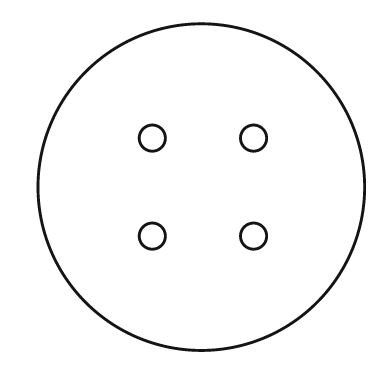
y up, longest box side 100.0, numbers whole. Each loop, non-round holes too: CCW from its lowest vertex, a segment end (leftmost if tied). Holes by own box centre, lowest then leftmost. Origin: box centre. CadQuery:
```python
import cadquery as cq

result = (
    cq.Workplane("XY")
    .moveTo(0.0, 0.0)
    .circle(50.0)
    .moveTo(-15.0, -15.0)
    .circle(4.0)
    .moveTo(16.0, -15.0)
    .circle(4.0)
    .moveTo(-15.0, 15.0)
    .circle(4.0)
    .moveTo(16.0, 15.0)
    .circle(4.0)
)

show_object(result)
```